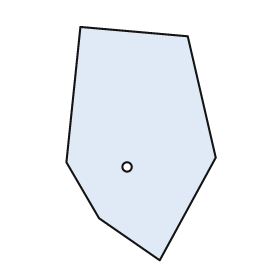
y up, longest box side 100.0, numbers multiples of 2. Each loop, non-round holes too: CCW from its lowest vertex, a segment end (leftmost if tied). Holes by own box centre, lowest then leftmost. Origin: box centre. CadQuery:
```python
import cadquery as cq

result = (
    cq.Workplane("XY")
    .moveTo(8.0, -50.0)
    .lineTo(32.0, -6.0)
    .lineTo(20.0, 46.0)
    .lineTo(-26.0, 50.0)
    .lineTo(-32.0, -8.0)
    .lineTo(-18.0, -32.0)
    .close()
    .moveTo(-6.0, -10.0)
    .circle(2.0)
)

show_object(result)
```